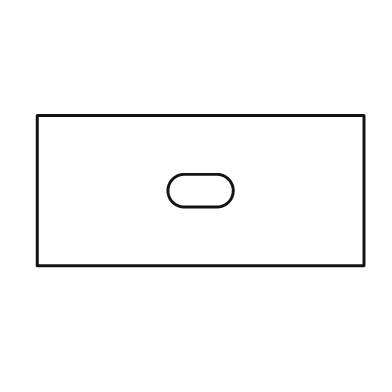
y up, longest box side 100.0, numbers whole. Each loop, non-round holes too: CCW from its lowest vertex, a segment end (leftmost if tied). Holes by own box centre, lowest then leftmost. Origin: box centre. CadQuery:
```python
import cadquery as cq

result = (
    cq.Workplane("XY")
    .moveTo(-50.0, -23.0)
    .lineTo(50.0, -23.0)
    .lineTo(50.0, 23.0)
    .lineTo(-50.0, 23.0)
    .close()
    .moveTo(-5.0, -5.0)
    .lineTo(5.0, -5.0)
    .threePointArc((10.0, 0.0), (5.0, 5.0))
    .lineTo(-5.0, 5.0)
    .threePointArc((-10.0, 0.0), (-5.0, -5.0))
    .close()
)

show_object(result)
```